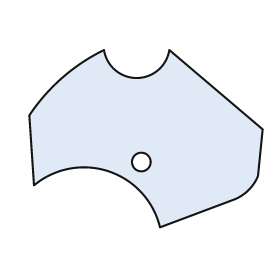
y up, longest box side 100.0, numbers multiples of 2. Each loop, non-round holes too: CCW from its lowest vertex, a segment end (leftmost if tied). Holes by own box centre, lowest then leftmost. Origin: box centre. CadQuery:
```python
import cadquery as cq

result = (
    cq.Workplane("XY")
    .moveTo(6.0, -38.0)
    .lineTo(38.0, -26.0)
    .threePointArc((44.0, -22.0), (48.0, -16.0))
    .lineTo(50.0, 4.0)
    .lineTo(10.0, 38.0)
    .threePointArc((-4.0, 26.0), (-18.0, 38.0))
    .threePointArc((-36.0, 26.0), (-50.0, 10.0))
    .lineTo(-48.0, -20.0)
    .threePointArc((-16.0, -14.0), (6.0, -38.0))
    .close()
    .moveTo(-2.0, -10.0)
    .circle(4.0)
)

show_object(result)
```